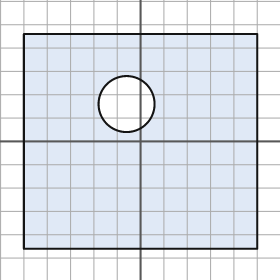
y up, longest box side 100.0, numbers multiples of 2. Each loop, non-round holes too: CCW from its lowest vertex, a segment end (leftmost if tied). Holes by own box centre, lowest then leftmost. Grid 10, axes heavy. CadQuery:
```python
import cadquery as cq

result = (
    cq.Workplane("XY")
    .moveTo(-50.0, -46.0)
    .lineTo(50.0, -46.0)
    .lineTo(50.0, 46.0)
    .lineTo(-50.0, 46.0)
    .close()
    .moveTo(-6.0, 16.0)
    .circle(12.0)
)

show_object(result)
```